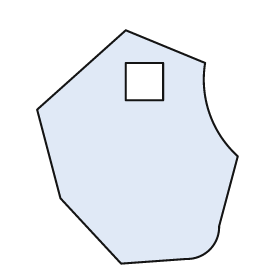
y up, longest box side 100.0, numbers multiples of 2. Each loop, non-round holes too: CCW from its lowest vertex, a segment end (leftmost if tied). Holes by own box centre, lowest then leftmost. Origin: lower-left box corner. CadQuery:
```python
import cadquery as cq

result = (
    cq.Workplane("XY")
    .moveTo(36.0, 0.0)
    .lineTo(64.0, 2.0)
    .threePointArc((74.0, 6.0), (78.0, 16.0))
    .lineTo(86.0, 46.0)
    .threePointArc((74.0, 64.0), (72.0, 86.0))
    .lineTo(38.0, 100.0)
    .lineTo(0.0, 66.0)
    .lineTo(10.0, 28.0)
    .close()
    .moveTo(38.0, 70.0)
    .lineTo(54.0, 70.0)
    .lineTo(54.0, 86.0)
    .lineTo(38.0, 86.0)
    .close()
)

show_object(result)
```